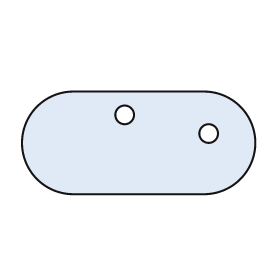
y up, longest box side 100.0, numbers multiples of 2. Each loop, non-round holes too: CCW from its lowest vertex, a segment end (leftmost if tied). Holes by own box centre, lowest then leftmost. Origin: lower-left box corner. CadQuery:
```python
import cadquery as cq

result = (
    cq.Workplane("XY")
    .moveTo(22.0, 0.0)
    .lineTo(78.0, 0.0)
    .threePointArc((100.0, 22.0), (78.0, 44.0))
    .lineTo(22.0, 44.0)
    .threePointArc((0.0, 22.0), (22.0, 0.0))
    .close()
    .moveTo(80.0, 26.0)
    .circle(4.0)
    .moveTo(44.0, 34.0)
    .circle(4.0)
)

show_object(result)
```